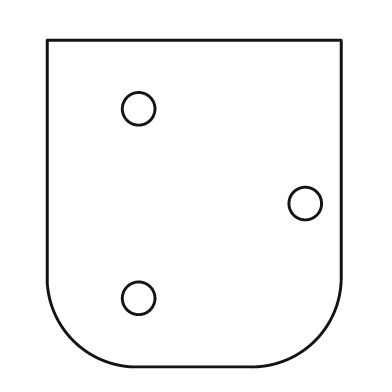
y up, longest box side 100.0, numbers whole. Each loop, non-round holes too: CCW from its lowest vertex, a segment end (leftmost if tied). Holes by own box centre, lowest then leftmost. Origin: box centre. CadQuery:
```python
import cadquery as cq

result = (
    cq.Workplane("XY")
    .moveTo(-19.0, -50.0)
    .lineTo(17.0, -50.0)
    .threePointArc((37.0, -42.0), (45.0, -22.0))
    .lineTo(45.0, 50.0)
    .lineTo(-45.0, 50.0)
    .lineTo(-45.0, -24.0)
    .threePointArc((-37.0, -42.0), (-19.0, -50.0))
    .close()
    .moveTo(-17.0, -29.0)
    .circle(5.0)
    .moveTo(34.0, 0.0)
    .circle(5.0)
    .moveTo(-17.0, 29.0)
    .circle(5.0)
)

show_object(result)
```